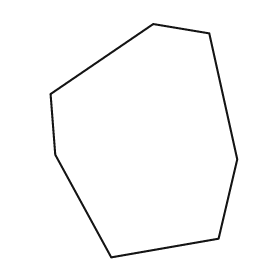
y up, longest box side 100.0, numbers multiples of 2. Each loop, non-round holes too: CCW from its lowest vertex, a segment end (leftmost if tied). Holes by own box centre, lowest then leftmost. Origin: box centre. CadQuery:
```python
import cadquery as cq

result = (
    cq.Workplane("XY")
    .moveTo(-14.0, -50.0)
    .lineTo(32.0, -42.0)
    .lineTo(40.0, -8.0)
    .lineTo(28.0, 46.0)
    .lineTo(4.0, 50.0)
    .lineTo(-40.0, 20.0)
    .lineTo(-38.0, -6.0)
    .close()
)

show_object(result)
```